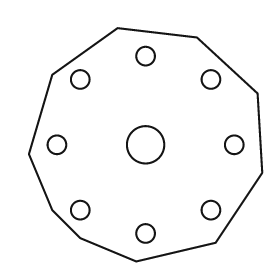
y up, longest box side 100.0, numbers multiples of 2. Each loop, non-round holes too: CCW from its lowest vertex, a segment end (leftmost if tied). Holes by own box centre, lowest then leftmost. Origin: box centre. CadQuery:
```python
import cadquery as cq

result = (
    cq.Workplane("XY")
    .moveTo(-4.0, -50.0)
    .lineTo(30.0, -42.0)
    .lineTo(50.0, -12.0)
    .lineTo(48.0, 22.0)
    .lineTo(22.0, 46.0)
    .lineTo(-12.0, 50.0)
    .lineTo(-40.0, 30.0)
    .lineTo(-50.0, -4.0)
    .lineTo(-40.0, -28.0)
    .lineTo(-28.0, -40.0)
    .close()
    .moveTo(0.0, -38.0)
    .circle(4.0)
    .moveTo(-28.0, -28.0)
    .circle(4.0)
    .moveTo(28.0, -28.0)
    .circle(4.0)
    .moveTo(-38.0, 0.0)
    .circle(4.0)
    .moveTo(0.0, 0.0)
    .circle(8.0)
    .moveTo(38.0, 0.0)
    .circle(4.0)
    .moveTo(-28.0, 28.0)
    .circle(4.0)
    .moveTo(28.0, 28.0)
    .circle(4.0)
    .moveTo(0.0, 38.0)
    .circle(4.0)
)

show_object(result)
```